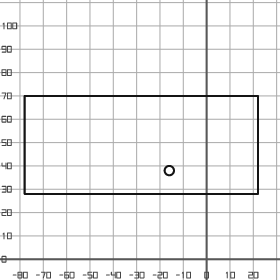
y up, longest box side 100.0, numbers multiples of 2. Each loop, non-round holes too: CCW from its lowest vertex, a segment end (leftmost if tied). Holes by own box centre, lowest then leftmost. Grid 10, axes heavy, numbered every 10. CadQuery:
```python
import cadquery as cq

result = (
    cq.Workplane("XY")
    .moveTo(-78.0, 28.0)
    .lineTo(22.0, 28.0)
    .lineTo(22.0, 70.0)
    .lineTo(-78.0, 70.0)
    .close()
    .moveTo(-16.0, 38.0)
    .circle(2.0)
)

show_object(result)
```